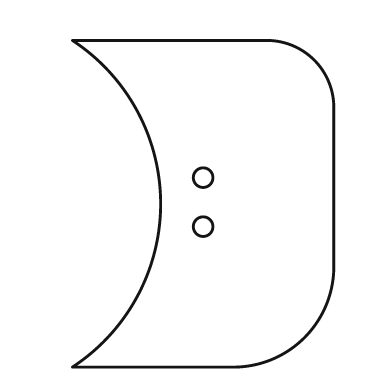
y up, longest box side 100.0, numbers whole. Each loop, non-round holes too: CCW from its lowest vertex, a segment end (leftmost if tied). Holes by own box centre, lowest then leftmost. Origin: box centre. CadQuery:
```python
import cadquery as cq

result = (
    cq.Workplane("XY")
    .moveTo(-40.0, -50.0)
    .lineTo(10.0, -50.0)
    .threePointArc((31.0, -41.0), (40.0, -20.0))
    .lineTo(40.0, 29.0)
    .threePointArc((34.0, 44.0), (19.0, 50.0))
    .lineTo(-40.0, 50.0)
    .threePointArc((-13.0, 0.0), (-40.0, -50.0))
    .close()
    .moveTo(0.0, -7.0)
    .circle(3.0)
    .moveTo(0.0, 8.0)
    .circle(3.0)
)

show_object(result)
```